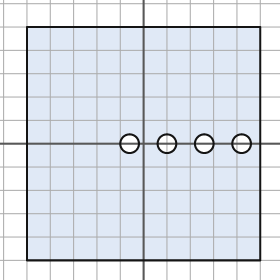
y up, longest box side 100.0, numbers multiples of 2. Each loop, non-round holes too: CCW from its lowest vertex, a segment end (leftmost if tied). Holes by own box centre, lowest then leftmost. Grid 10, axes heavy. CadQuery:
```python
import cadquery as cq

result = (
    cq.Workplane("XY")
    .moveTo(-50.0, -50.0)
    .lineTo(50.0, -50.0)
    .lineTo(50.0, 50.0)
    .lineTo(-50.0, 50.0)
    .close()
    .moveTo(-6.0, 0.0)
    .circle(4.0)
    .moveTo(10.0, 0.0)
    .circle(4.0)
    .moveTo(26.0, 0.0)
    .circle(4.0)
    .moveTo(42.0, 0.0)
    .circle(4.0)
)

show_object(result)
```